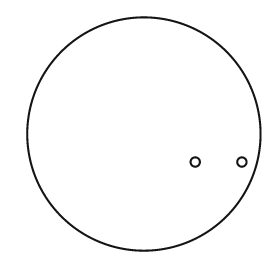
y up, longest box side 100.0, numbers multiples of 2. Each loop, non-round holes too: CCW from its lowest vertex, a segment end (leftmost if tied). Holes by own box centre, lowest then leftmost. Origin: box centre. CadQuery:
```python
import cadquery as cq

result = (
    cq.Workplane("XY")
    .moveTo(0.0, 0.0)
    .circle(50.0)
    .moveTo(22.0, -12.0)
    .circle(2.0)
    .moveTo(42.0, -12.0)
    .circle(2.0)
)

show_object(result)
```